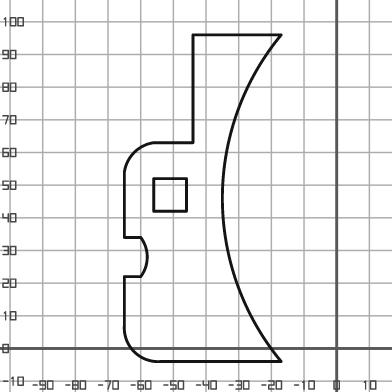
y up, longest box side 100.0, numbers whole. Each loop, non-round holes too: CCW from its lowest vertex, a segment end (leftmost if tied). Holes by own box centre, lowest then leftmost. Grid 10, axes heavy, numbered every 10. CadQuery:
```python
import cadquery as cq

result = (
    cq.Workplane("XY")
    .moveTo(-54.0, -4.0)
    .lineTo(-17.0, -4.0)
    .threePointArc((-35.0, 46.0), (-17.0, 96.0))
    .lineTo(-44.0, 96.0)
    .lineTo(-44.0, 63.0)
    .lineTo(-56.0, 63.0)
    .threePointArc((-62.0, 60.0), (-65.0, 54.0))
    .lineTo(-65.0, 34.0)
    .lineTo(-60.0, 34.0)
    .threePointArc((-58.0, 28.0), (-60.0, 22.0))
    .lineTo(-65.0, 22.0)
    .lineTo(-65.0, 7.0)
    .threePointArc((-62.0, -1.0), (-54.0, -4.0))
    .close()
    .moveTo(-56.0, 42.0)
    .lineTo(-46.0, 42.0)
    .lineTo(-46.0, 52.0)
    .lineTo(-56.0, 52.0)
    .close()
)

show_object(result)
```